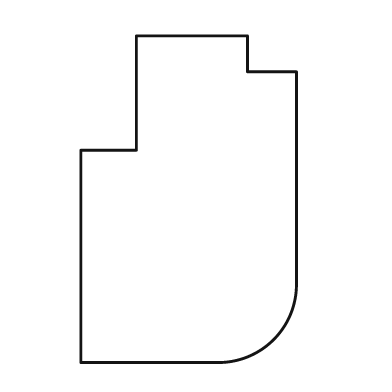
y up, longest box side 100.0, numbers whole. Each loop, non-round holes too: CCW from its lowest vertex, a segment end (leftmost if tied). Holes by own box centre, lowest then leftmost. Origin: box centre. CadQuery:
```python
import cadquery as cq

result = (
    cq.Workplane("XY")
    .moveTo(-33.0, -50.0)
    .lineTo(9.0, -50.0)
    .threePointArc((26.0, -43.0), (33.0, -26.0))
    .lineTo(33.0, 39.0)
    .lineTo(18.0, 39.0)
    .lineTo(18.0, 50.0)
    .lineTo(-16.0, 50.0)
    .lineTo(-16.0, 15.0)
    .lineTo(-33.0, 15.0)
    .close()
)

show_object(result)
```